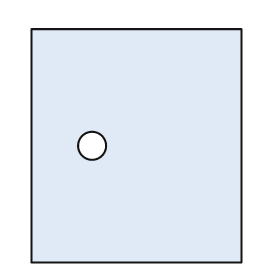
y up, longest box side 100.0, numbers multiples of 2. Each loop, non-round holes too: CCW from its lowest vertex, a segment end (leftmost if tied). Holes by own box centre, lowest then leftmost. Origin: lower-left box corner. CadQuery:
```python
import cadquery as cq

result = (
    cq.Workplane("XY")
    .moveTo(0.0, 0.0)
    .lineTo(90.0, 0.0)
    .lineTo(90.0, 100.0)
    .lineTo(0.0, 100.0)
    .close()
    .moveTo(26.0, 50.0)
    .circle(6.0)
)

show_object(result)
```